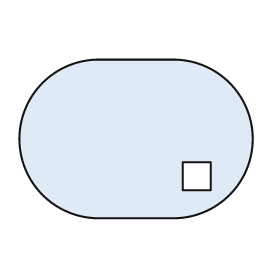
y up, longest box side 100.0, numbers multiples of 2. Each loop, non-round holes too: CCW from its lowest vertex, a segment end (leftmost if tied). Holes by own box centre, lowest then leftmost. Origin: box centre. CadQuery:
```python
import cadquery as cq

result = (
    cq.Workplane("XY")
    .moveTo(-16.0, -34.0)
    .lineTo(16.0, -34.0)
    .threePointArc((50.0, 0.0), (16.0, 34.0))
    .lineTo(-16.0, 34.0)
    .threePointArc((-50.0, 0.0), (-16.0, -34.0))
    .close()
    .moveTo(20.0, -22.0)
    .lineTo(32.0, -22.0)
    .lineTo(32.0, -10.0)
    .lineTo(20.0, -10.0)
    .close()
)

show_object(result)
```